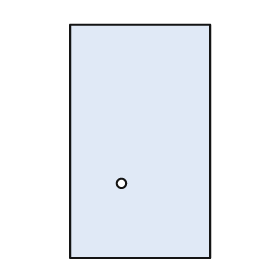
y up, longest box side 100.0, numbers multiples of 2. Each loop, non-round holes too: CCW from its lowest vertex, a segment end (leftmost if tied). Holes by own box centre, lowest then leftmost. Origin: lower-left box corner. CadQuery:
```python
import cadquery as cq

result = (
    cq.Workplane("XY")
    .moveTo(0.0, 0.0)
    .lineTo(60.0, 0.0)
    .lineTo(60.0, 100.0)
    .lineTo(0.0, 100.0)
    .close()
    .moveTo(22.0, 32.0)
    .circle(2.0)
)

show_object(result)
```